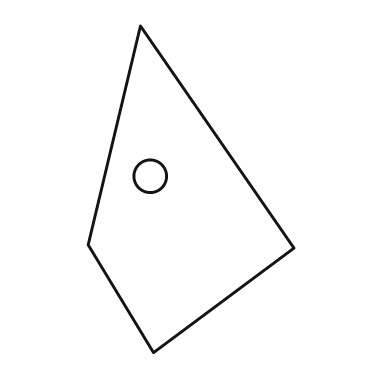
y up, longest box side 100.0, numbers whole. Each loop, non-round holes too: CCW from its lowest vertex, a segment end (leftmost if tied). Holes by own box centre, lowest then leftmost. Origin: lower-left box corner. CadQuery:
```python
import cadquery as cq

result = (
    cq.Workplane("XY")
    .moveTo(20.0, 0.0)
    .lineTo(63.0, 32.0)
    .lineTo(16.0, 100.0)
    .lineTo(0.0, 33.0)
    .close()
    .moveTo(19.0, 54.0)
    .circle(5.0)
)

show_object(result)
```